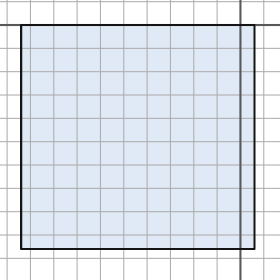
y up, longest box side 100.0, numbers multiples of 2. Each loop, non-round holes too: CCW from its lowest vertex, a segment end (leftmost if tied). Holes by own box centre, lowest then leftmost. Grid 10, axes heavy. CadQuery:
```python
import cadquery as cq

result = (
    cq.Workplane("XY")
    .moveTo(-94.0, -96.0)
    .lineTo(6.0, -96.0)
    .lineTo(6.0, 0.0)
    .lineTo(-94.0, 0.0)
    .close()
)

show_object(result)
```